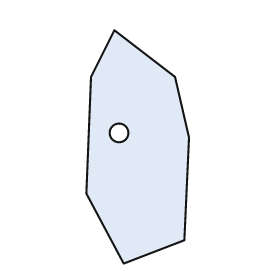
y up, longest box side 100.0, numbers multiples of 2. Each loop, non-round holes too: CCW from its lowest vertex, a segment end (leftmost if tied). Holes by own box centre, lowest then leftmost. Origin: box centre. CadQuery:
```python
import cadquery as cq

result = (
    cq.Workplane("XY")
    .moveTo(-6.0, -50.0)
    .lineTo(20.0, -40.0)
    .lineTo(22.0, 4.0)
    .lineTo(16.0, 30.0)
    .lineTo(-10.0, 50.0)
    .lineTo(-20.0, 30.0)
    .lineTo(-22.0, -20.0)
    .close()
    .moveTo(-8.0, 6.0)
    .circle(4.0)
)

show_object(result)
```